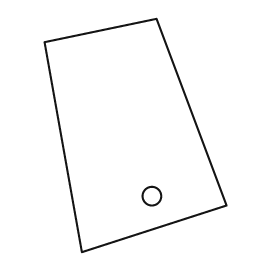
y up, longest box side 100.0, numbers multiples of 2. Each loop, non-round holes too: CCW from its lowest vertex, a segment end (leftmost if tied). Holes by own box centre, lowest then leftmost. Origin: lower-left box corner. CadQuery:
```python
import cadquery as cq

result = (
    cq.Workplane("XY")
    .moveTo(16.0, 0.0)
    .lineTo(78.0, 20.0)
    .lineTo(48.0, 100.0)
    .lineTo(0.0, 90.0)
    .close()
    .moveTo(46.0, 24.0)
    .circle(4.0)
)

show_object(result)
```